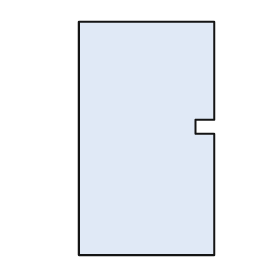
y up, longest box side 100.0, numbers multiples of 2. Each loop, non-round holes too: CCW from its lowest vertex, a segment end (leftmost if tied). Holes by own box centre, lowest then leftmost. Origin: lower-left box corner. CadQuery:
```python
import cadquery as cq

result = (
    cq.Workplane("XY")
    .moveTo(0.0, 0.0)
    .lineTo(58.0, 0.0)
    .lineTo(58.0, 52.0)
    .lineTo(50.0, 52.0)
    .lineTo(50.0, 58.0)
    .lineTo(58.0, 58.0)
    .lineTo(58.0, 100.0)
    .lineTo(0.0, 100.0)
    .close()
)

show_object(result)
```